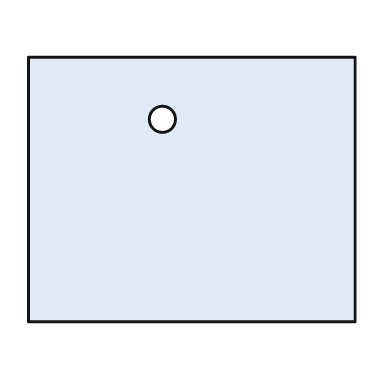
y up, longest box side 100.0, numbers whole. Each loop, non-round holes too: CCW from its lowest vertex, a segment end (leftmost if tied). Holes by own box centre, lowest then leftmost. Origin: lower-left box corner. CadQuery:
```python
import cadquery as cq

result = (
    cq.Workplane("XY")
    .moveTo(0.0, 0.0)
    .lineTo(100.0, 0.0)
    .lineTo(100.0, 81.0)
    .lineTo(0.0, 81.0)
    .close()
    .moveTo(41.0, 62.0)
    .circle(4.0)
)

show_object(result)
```